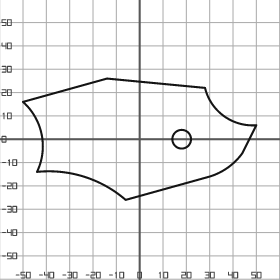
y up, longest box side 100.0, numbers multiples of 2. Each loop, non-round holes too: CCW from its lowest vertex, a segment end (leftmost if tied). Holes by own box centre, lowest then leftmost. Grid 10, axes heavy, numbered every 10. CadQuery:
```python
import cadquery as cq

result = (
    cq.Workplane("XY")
    .moveTo(-6.0, -26.0)
    .lineTo(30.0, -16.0)
    .threePointArc((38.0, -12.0), (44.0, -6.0))
    .lineTo(50.0, 6.0)
    .threePointArc((36.0, 10.0), (28.0, 22.0))
    .lineTo(-14.0, 26.0)
    .lineTo(-50.0, 16.0)
    .threePointArc((-42.0, 2.0), (-44.0, -14.0))
    .threePointArc((-24.0, -16.0), (-6.0, -26.0))
    .close()
    .moveTo(18.0, 0.0)
    .circle(4.0)
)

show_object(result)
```